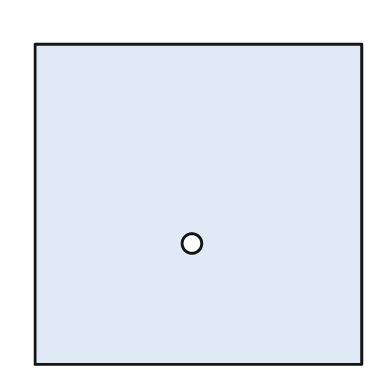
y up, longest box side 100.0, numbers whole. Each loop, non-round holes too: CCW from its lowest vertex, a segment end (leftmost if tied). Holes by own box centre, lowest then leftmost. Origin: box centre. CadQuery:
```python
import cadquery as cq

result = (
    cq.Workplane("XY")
    .moveTo(-50.0, -49.0)
    .lineTo(50.0, -49.0)
    .lineTo(50.0, 49.0)
    .lineTo(-50.0, 49.0)
    .close()
    .moveTo(-2.0, -12.0)
    .circle(3.0)
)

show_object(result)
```